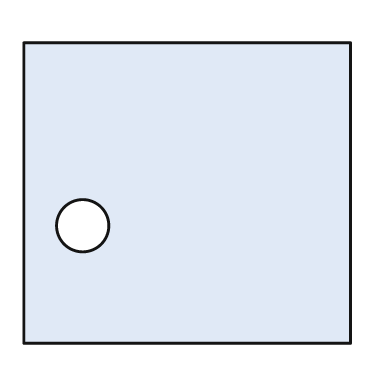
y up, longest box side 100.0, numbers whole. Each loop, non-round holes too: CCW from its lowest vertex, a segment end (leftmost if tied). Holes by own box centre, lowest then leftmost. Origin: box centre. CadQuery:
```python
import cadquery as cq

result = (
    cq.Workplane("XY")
    .moveTo(-50.0, -46.0)
    .lineTo(50.0, -46.0)
    .lineTo(50.0, 46.0)
    .lineTo(-50.0, 46.0)
    .close()
    .moveTo(-32.0, -10.0)
    .circle(8.0)
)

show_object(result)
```